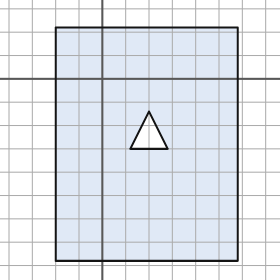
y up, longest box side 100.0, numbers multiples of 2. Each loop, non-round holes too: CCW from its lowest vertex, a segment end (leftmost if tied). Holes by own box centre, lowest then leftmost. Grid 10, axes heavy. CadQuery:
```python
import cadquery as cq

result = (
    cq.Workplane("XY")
    .moveTo(-20.0, -78.0)
    .lineTo(58.0, -78.0)
    .lineTo(58.0, 22.0)
    .lineTo(-20.0, 22.0)
    .close()
    .moveTo(12.0, -30.0)
    .lineTo(28.0, -30.0)
    .lineTo(20.0, -14.0)
    .close()
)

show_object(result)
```